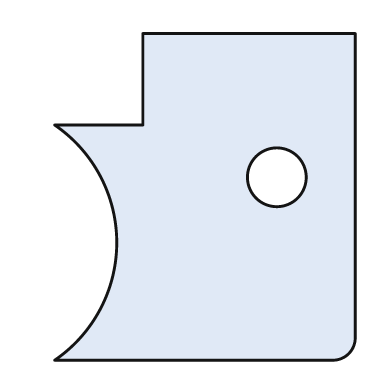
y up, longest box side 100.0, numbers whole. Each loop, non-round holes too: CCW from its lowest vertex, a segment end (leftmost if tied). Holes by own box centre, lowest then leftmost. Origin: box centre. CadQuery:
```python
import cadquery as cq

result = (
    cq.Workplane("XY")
    .moveTo(-46.0, -50.0)
    .lineTo(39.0, -50.0)
    .threePointArc((44.0, -48.0), (46.0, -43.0))
    .lineTo(46.0, 50.0)
    .lineTo(-19.0, 50.0)
    .lineTo(-19.0, 22.0)
    .lineTo(-46.0, 22.0)
    .threePointArc((-27.0, -14.0), (-46.0, -50.0))
    .close()
    .moveTo(22.0, 6.0)
    .circle(9.0)
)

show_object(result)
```